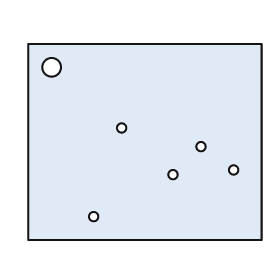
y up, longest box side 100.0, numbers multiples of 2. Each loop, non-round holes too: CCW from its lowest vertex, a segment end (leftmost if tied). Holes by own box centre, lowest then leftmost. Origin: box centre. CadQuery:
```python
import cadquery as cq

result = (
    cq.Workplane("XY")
    .moveTo(-50.0, -42.0)
    .lineTo(50.0, -42.0)
    .lineTo(50.0, 42.0)
    .lineTo(-50.0, 42.0)
    .close()
    .moveTo(-22.0, -32.0)
    .circle(2.0)
    .moveTo(12.0, -14.0)
    .circle(2.0)
    .moveTo(38.0, -12.0)
    .circle(2.0)
    .moveTo(24.0, -2.0)
    .circle(2.0)
    .moveTo(-10.0, 6.0)
    .circle(2.0)
    .moveTo(-40.0, 32.0)
    .circle(4.0)
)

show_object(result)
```